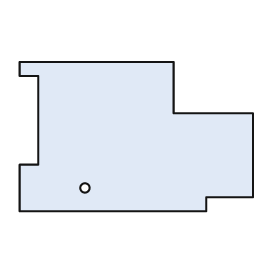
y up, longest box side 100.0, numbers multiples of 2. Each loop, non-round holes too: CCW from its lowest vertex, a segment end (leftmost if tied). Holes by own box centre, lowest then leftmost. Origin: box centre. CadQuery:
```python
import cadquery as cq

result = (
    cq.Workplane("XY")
    .moveTo(-50.0, -32.0)
    .lineTo(30.0, -32.0)
    .lineTo(30.0, -26.0)
    .lineTo(50.0, -26.0)
    .lineTo(50.0, 10.0)
    .lineTo(16.0, 10.0)
    .lineTo(16.0, 32.0)
    .lineTo(-50.0, 32.0)
    .lineTo(-50.0, 26.0)
    .lineTo(-42.0, 26.0)
    .lineTo(-42.0, -12.0)
    .lineTo(-50.0, -12.0)
    .close()
    .moveTo(-22.0, -22.0)
    .circle(2.0)
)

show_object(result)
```